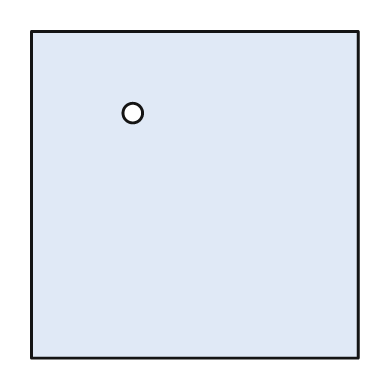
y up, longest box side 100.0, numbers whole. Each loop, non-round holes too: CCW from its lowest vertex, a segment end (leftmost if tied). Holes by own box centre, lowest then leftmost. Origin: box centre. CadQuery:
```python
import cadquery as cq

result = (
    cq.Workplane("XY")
    .moveTo(-50.0, -50.0)
    .lineTo(50.0, -50.0)
    .lineTo(50.0, 50.0)
    .lineTo(-50.0, 50.0)
    .close()
    .moveTo(-19.0, 25.0)
    .circle(3.0)
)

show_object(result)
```